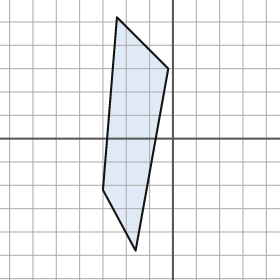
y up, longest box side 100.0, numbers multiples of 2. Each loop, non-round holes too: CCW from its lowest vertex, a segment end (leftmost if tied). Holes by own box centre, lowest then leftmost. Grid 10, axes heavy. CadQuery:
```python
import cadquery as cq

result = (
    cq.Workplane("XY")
    .moveTo(-16.0, -48.0)
    .lineTo(-2.0, 30.0)
    .lineTo(-24.0, 52.0)
    .lineTo(-30.0, -22.0)
    .close()
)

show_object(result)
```